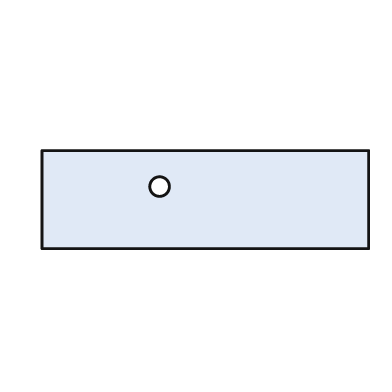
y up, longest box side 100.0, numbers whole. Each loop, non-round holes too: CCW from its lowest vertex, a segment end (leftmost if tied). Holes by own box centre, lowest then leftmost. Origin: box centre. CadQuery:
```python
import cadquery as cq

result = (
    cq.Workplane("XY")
    .moveTo(-50.0, -15.0)
    .lineTo(50.0, -15.0)
    .lineTo(50.0, 15.0)
    .lineTo(-50.0, 15.0)
    .close()
    .moveTo(-14.0, 4.0)
    .circle(3.0)
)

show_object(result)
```